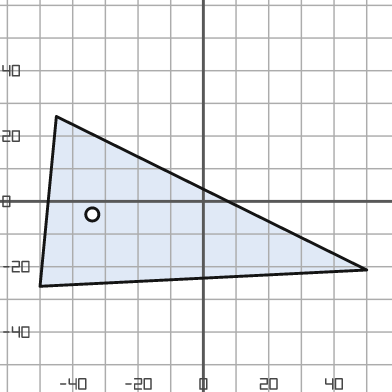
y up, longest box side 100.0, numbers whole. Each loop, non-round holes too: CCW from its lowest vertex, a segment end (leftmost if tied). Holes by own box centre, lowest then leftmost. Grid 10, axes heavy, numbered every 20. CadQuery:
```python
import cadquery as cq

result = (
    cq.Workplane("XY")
    .moveTo(-50.0, -26.0)
    .lineTo(50.0, -21.0)
    .lineTo(-45.0, 26.0)
    .close()
    .moveTo(-34.0, -4.0)
    .circle(2.0)
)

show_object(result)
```